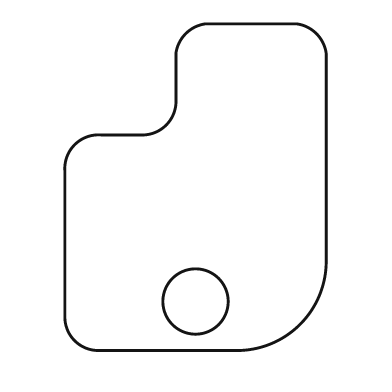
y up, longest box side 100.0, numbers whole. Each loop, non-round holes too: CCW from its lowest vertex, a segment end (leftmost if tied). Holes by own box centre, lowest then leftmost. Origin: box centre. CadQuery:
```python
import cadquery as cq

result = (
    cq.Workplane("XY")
    .moveTo(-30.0, -50.0)
    .lineTo(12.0, -50.0)
    .threePointArc((32.0, -42.0), (40.0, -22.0))
    .lineTo(40.0, 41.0)
    .threePointArc((37.0, 47.0), (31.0, 50.0))
    .lineTo(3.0, 50.0)
    .threePointArc((-3.0, 47.0), (-6.0, 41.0))
    .lineTo(-6.0, 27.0)
    .threePointArc((-9.0, 19.0), (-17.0, 16.0))
    .lineTo(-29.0, 16.0)
    .threePointArc((-37.0, 13.0), (-40.0, 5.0))
    .lineTo(-40.0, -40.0)
    .threePointArc((-37.0, -47.0), (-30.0, -50.0))
    .close()
    .moveTo(0.0, -35.0)
    .circle(10.0)
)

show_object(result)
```